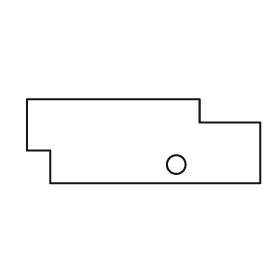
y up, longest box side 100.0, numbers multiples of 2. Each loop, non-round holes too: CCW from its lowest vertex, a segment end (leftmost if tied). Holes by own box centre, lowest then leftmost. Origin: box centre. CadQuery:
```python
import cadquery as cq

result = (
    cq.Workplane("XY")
    .moveTo(-40.0, -18.0)
    .lineTo(50.0, -18.0)
    .lineTo(50.0, 8.0)
    .lineTo(24.0, 8.0)
    .lineTo(24.0, 18.0)
    .lineTo(-50.0, 18.0)
    .lineTo(-50.0, -4.0)
    .lineTo(-40.0, -4.0)
    .close()
    .moveTo(14.0, -10.0)
    .circle(4.0)
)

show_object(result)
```